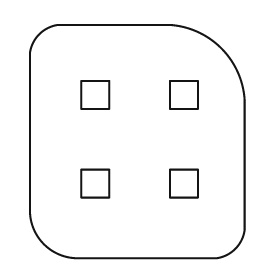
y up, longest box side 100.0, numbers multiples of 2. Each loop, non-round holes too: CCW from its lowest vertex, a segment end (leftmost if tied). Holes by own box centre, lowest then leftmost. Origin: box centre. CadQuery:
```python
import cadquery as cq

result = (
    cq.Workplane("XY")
    .moveTo(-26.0, -50.0)
    .lineTo(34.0, -50.0)
    .threePointArc((42.0, -46.0), (46.0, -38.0))
    .lineTo(46.0, 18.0)
    .threePointArc((36.0, 40.0), (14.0, 50.0))
    .lineTo(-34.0, 50.0)
    .threePointArc((-42.0, 46.0), (-46.0, 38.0))
    .lineTo(-46.0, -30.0)
    .threePointArc((-40.0, -44.0), (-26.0, -50.0))
    .close()
    .moveTo(-24.0, -24.0)
    .lineTo(-12.0, -24.0)
    .lineTo(-12.0, -12.0)
    .lineTo(-24.0, -12.0)
    .close()
    .moveTo(14.0, -24.0)
    .lineTo(26.0, -24.0)
    .lineTo(26.0, -12.0)
    .lineTo(14.0, -12.0)
    .close()
    .moveTo(-24.0, 14.0)
    .lineTo(-12.0, 14.0)
    .lineTo(-12.0, 26.0)
    .lineTo(-24.0, 26.0)
    .close()
    .moveTo(14.0, 14.0)
    .lineTo(26.0, 14.0)
    .lineTo(26.0, 26.0)
    .lineTo(14.0, 26.0)
    .close()
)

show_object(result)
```